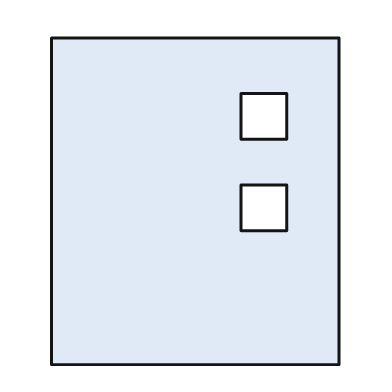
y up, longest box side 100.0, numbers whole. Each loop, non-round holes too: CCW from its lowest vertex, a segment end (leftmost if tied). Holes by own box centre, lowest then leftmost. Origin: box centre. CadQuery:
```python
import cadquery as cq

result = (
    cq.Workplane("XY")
    .moveTo(-44.0, -50.0)
    .lineTo(44.0, -50.0)
    .lineTo(44.0, 50.0)
    .lineTo(-44.0, 50.0)
    .close()
    .moveTo(14.0, -9.0)
    .lineTo(28.0, -9.0)
    .lineTo(28.0, 5.0)
    .lineTo(14.0, 5.0)
    .close()
    .moveTo(14.0, 19.0)
    .lineTo(28.0, 19.0)
    .lineTo(28.0, 33.0)
    .lineTo(14.0, 33.0)
    .close()
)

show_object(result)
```